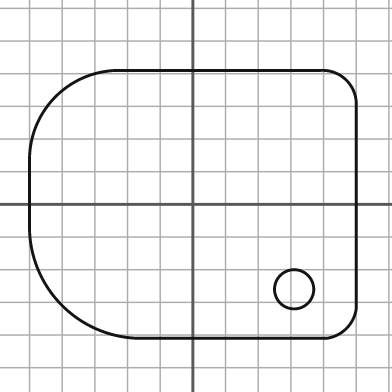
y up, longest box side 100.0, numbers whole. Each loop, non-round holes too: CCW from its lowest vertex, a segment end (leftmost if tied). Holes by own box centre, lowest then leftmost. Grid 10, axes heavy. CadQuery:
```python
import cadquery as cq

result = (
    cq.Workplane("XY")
    .moveTo(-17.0, -41.0)
    .lineTo(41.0, -41.0)
    .threePointArc((47.0, -38.0), (50.0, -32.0))
    .lineTo(50.0, 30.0)
    .threePointArc((47.0, 38.0), (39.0, 41.0))
    .lineTo(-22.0, 41.0)
    .threePointArc((-42.0, 33.0), (-50.0, 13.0))
    .lineTo(-50.0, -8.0)
    .threePointArc((-40.0, -31.0), (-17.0, -41.0))
    .close()
    .moveTo(31.0, -26.0)
    .circle(6.0)
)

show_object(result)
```